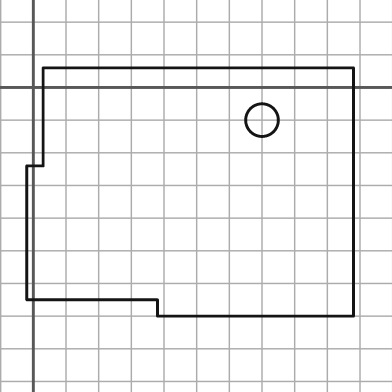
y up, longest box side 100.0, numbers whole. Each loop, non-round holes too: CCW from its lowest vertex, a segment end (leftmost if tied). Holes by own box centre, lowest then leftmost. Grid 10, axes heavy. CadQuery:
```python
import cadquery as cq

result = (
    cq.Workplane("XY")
    .moveTo(38.0, -70.0)
    .lineTo(98.0, -70.0)
    .lineTo(98.0, 6.0)
    .lineTo(3.0, 6.0)
    .lineTo(3.0, -24.0)
    .lineTo(-2.0, -24.0)
    .lineTo(-2.0, -65.0)
    .lineTo(38.0, -65.0)
    .close()
    .moveTo(70.0, -10.0)
    .circle(5.0)
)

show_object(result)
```